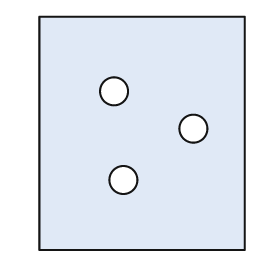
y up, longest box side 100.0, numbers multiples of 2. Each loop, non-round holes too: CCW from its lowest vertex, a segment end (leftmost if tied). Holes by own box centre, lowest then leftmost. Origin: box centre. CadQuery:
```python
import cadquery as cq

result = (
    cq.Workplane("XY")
    .moveTo(-44.0, -50.0)
    .lineTo(44.0, -50.0)
    .lineTo(44.0, 50.0)
    .lineTo(-44.0, 50.0)
    .close()
    .moveTo(-8.0, -20.0)
    .circle(6.0)
    .moveTo(22.0, 2.0)
    .circle(6.0)
    .moveTo(-12.0, 18.0)
    .circle(6.0)
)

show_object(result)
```